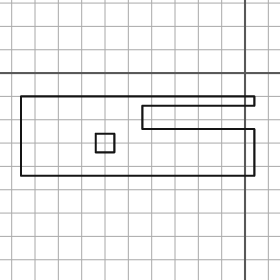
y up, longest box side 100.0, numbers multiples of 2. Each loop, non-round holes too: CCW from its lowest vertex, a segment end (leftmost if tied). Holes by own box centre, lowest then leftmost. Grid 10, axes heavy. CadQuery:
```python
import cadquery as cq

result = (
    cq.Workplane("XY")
    .moveTo(-96.0, -44.0)
    .lineTo(4.0, -44.0)
    .lineTo(4.0, -24.0)
    .lineTo(-44.0, -24.0)
    .lineTo(-44.0, -14.0)
    .lineTo(4.0, -14.0)
    .lineTo(4.0, -10.0)
    .lineTo(-96.0, -10.0)
    .close()
    .moveTo(-64.0, -34.0)
    .lineTo(-56.0, -34.0)
    .lineTo(-56.0, -26.0)
    .lineTo(-64.0, -26.0)
    .close()
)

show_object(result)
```